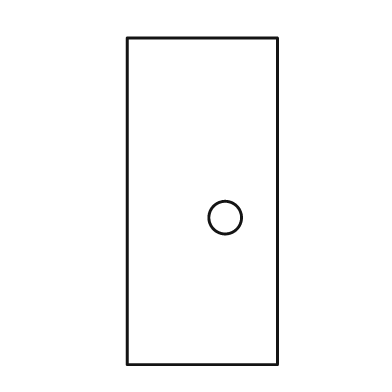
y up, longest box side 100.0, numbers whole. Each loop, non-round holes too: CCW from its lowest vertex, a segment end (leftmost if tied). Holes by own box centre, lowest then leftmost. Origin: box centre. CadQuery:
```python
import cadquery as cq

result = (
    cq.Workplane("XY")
    .moveTo(-23.0, -50.0)
    .lineTo(23.0, -50.0)
    .lineTo(23.0, 50.0)
    .lineTo(-23.0, 50.0)
    .close()
    .moveTo(7.0, -5.0)
    .circle(5.0)
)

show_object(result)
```